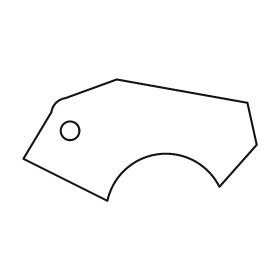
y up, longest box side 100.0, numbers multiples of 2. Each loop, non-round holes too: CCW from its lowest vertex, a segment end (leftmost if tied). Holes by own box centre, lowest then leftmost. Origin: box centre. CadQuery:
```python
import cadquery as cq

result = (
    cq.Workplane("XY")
    .moveTo(-14.0, -26.0)
    .threePointArc((8.0, -6.0), (34.0, -20.0))
    .lineTo(50.0, -2.0)
    .lineTo(46.0, 16.0)
    .lineTo(-10.0, 26.0)
    .lineTo(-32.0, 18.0)
    .threePointArc((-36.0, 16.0), (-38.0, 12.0))
    .lineTo(-50.0, -8.0)
    .close()
    .moveTo(-30.0, 4.0)
    .circle(4.0)
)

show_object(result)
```